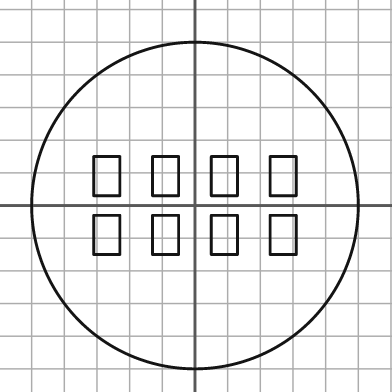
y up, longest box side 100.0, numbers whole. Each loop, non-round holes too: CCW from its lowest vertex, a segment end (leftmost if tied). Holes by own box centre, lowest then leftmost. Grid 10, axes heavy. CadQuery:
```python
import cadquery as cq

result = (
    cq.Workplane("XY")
    .moveTo(0.0, 0.0)
    .circle(50.0)
    .moveTo(-31.0, -15.0)
    .lineTo(-23.0, -15.0)
    .lineTo(-23.0, -3.0)
    .lineTo(-31.0, -3.0)
    .close()
    .moveTo(-13.0, -15.0)
    .lineTo(-5.0, -15.0)
    .lineTo(-5.0, -3.0)
    .lineTo(-13.0, -3.0)
    .close()
    .moveTo(5.0, -15.0)
    .lineTo(13.0, -15.0)
    .lineTo(13.0, -3.0)
    .lineTo(5.0, -3.0)
    .close()
    .moveTo(23.0, -15.0)
    .lineTo(31.0, -15.0)
    .lineTo(31.0, -3.0)
    .lineTo(23.0, -3.0)
    .close()
    .moveTo(-31.0, 3.0)
    .lineTo(-23.0, 3.0)
    .lineTo(-23.0, 15.0)
    .lineTo(-31.0, 15.0)
    .close()
    .moveTo(-13.0, 3.0)
    .lineTo(-5.0, 3.0)
    .lineTo(-5.0, 15.0)
    .lineTo(-13.0, 15.0)
    .close()
    .moveTo(5.0, 3.0)
    .lineTo(13.0, 3.0)
    .lineTo(13.0, 15.0)
    .lineTo(5.0, 15.0)
    .close()
    .moveTo(23.0, 3.0)
    .lineTo(31.0, 3.0)
    .lineTo(31.0, 15.0)
    .lineTo(23.0, 15.0)
    .close()
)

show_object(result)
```